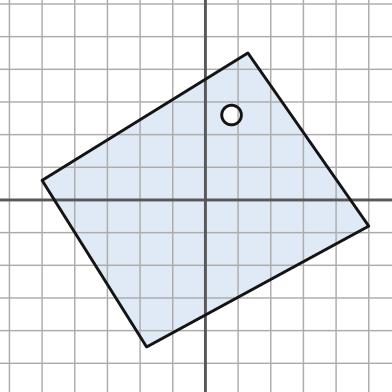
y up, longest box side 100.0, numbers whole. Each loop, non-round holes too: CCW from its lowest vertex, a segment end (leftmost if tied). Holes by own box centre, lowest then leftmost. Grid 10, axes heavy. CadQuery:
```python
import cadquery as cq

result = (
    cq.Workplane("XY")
    .moveTo(-18.0, -45.0)
    .lineTo(50.0, -8.0)
    .lineTo(13.0, 45.0)
    .lineTo(-50.0, 6.0)
    .close()
    .moveTo(8.0, 26.0)
    .circle(3.0)
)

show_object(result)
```